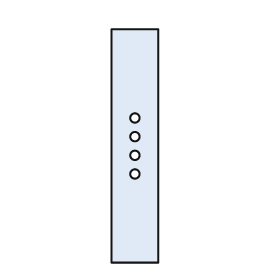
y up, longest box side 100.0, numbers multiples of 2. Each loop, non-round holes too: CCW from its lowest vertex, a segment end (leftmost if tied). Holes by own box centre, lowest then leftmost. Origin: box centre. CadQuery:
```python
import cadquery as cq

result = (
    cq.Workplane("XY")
    .moveTo(-10.0, -50.0)
    .lineTo(10.0, -50.0)
    .lineTo(10.0, 50.0)
    .lineTo(-10.0, 50.0)
    .close()
    .moveTo(0.0, -12.0)
    .circle(2.0)
    .moveTo(0.0, -4.0)
    .circle(2.0)
    .moveTo(0.0, 4.0)
    .circle(2.0)
    .moveTo(0.0, 12.0)
    .circle(2.0)
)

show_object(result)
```